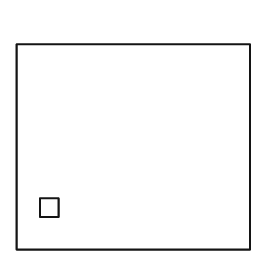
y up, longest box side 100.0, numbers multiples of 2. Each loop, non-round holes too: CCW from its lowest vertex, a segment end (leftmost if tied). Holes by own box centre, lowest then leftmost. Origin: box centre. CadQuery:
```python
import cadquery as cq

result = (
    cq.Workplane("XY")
    .moveTo(-50.0, -44.0)
    .lineTo(50.0, -44.0)
    .lineTo(50.0, 44.0)
    .lineTo(-50.0, 44.0)
    .close()
    .moveTo(-40.0, -30.0)
    .lineTo(-32.0, -30.0)
    .lineTo(-32.0, -22.0)
    .lineTo(-40.0, -22.0)
    .close()
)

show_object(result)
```